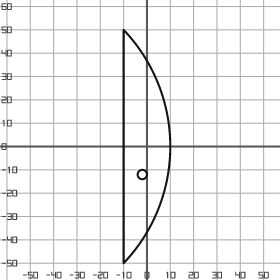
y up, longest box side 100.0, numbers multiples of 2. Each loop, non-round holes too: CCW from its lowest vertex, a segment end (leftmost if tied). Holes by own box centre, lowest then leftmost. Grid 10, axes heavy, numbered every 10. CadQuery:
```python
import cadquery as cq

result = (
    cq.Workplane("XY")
    .moveTo(-10.0, -50.0)
    .threePointArc((10.0, 0.0), (-10.0, 50.0))
    .close()
    .moveTo(-2.0, -12.0)
    .circle(2.0)
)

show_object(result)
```